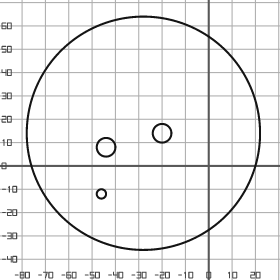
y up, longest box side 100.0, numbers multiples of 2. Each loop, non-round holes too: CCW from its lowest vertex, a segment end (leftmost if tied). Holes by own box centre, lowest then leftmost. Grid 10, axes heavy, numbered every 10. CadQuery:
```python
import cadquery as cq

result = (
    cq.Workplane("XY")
    .moveTo(-28.0, 14.0)
    .circle(50.0)
    .moveTo(-46.0, -12.0)
    .circle(2.0)
    .moveTo(-44.0, 8.0)
    .circle(4.0)
    .moveTo(-20.0, 14.0)
    .circle(4.0)
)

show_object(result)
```